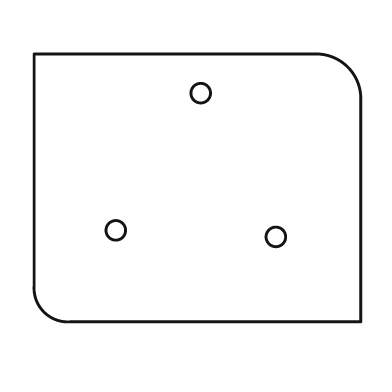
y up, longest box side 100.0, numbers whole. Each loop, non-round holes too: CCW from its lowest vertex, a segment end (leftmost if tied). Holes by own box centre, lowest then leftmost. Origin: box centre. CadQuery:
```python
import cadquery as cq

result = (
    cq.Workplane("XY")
    .moveTo(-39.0, -41.0)
    .lineTo(50.0, -41.0)
    .lineTo(50.0, 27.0)
    .threePointArc((46.0, 37.0), (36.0, 41.0))
    .lineTo(-50.0, 41.0)
    .lineTo(-50.0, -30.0)
    .threePointArc((-47.0, -38.0), (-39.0, -41.0))
    .close()
    .moveTo(24.0, -15.0)
    .circle(3.0)
    .moveTo(-25.0, -13.0)
    .circle(3.0)
    .moveTo(1.0, 29.0)
    .circle(3.0)
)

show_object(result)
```